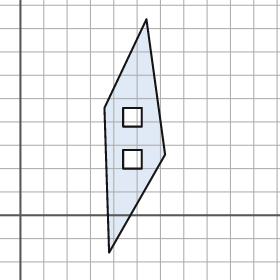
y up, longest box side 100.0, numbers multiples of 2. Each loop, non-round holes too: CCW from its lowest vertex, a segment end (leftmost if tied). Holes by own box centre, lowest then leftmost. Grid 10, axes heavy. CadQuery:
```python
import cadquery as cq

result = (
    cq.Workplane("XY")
    .moveTo(38.0, -16.0)
    .lineTo(62.0, 26.0)
    .lineTo(54.0, 84.0)
    .lineTo(36.0, 46.0)
    .close()
    .moveTo(44.0, 20.0)
    .lineTo(52.0, 20.0)
    .lineTo(52.0, 28.0)
    .lineTo(44.0, 28.0)
    .close()
    .moveTo(44.0, 38.0)
    .lineTo(52.0, 38.0)
    .lineTo(52.0, 46.0)
    .lineTo(44.0, 46.0)
    .close()
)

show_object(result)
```